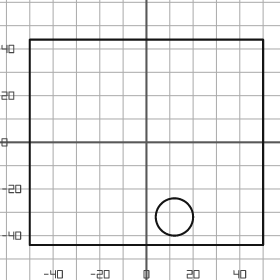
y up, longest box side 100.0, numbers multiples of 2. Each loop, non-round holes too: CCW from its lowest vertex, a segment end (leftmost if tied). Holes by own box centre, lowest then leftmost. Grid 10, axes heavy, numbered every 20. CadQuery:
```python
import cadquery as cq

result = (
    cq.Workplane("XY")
    .moveTo(-50.0, -44.0)
    .lineTo(50.0, -44.0)
    .lineTo(50.0, 44.0)
    .lineTo(-50.0, 44.0)
    .close()
    .moveTo(12.0, -32.0)
    .circle(8.0)
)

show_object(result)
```